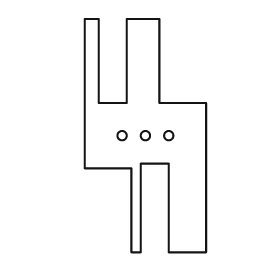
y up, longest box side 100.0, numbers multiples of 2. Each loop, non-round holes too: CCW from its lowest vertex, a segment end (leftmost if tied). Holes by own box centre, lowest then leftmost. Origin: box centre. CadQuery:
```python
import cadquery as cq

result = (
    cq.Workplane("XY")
    .moveTo(-6.0, -50.0)
    .lineTo(-2.0, -50.0)
    .lineTo(-2.0, -12.0)
    .lineTo(10.0, -12.0)
    .lineTo(10.0, -50.0)
    .lineTo(26.0, -50.0)
    .lineTo(26.0, 14.0)
    .lineTo(6.0, 14.0)
    .lineTo(6.0, 50.0)
    .lineTo(-8.0, 50.0)
    .lineTo(-8.0, 14.0)
    .lineTo(-20.0, 14.0)
    .lineTo(-20.0, 50.0)
    .lineTo(-26.0, 50.0)
    .lineTo(-26.0, -14.0)
    .lineTo(-6.0, -14.0)
    .close()
    .moveTo(-10.0, 0.0)
    .circle(2.0)
    .moveTo(0.0, 0.0)
    .circle(2.0)
    .moveTo(10.0, 0.0)
    .circle(2.0)
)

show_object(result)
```